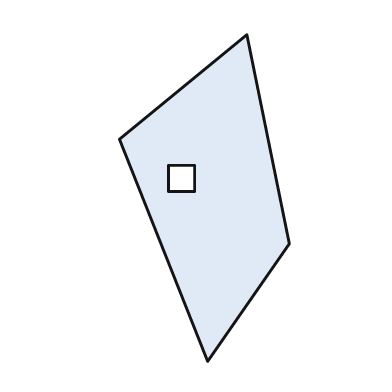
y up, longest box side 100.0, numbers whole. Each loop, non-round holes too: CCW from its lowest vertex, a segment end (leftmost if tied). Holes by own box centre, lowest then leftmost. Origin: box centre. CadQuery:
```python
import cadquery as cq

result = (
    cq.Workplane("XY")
    .moveTo(1.0, -50.0)
    .lineTo(26.0, -14.0)
    .lineTo(13.0, 50.0)
    .lineTo(-26.0, 18.0)
    .close()
    .moveTo(-11.0, 2.0)
    .lineTo(-3.0, 2.0)
    .lineTo(-3.0, 10.0)
    .lineTo(-11.0, 10.0)
    .close()
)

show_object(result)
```